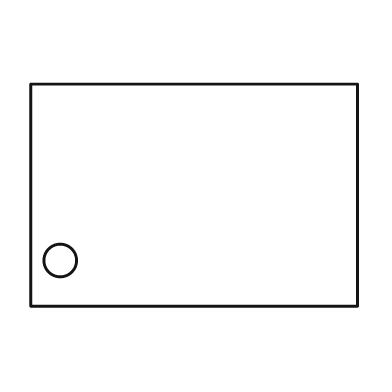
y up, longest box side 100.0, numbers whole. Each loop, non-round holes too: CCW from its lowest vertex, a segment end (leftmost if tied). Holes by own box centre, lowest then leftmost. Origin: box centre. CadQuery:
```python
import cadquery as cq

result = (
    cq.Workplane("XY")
    .moveTo(-50.0, -34.0)
    .lineTo(50.0, -34.0)
    .lineTo(50.0, 34.0)
    .lineTo(-50.0, 34.0)
    .close()
    .moveTo(-41.0, -20.0)
    .circle(5.0)
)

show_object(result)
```